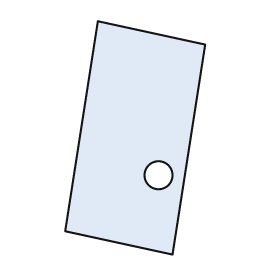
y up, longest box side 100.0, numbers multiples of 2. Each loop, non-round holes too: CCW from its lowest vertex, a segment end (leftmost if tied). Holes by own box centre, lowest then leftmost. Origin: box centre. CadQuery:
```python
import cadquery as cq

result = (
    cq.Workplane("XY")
    .moveTo(16.0, -50.0)
    .lineTo(30.0, 40.0)
    .lineTo(-16.0, 50.0)
    .lineTo(-30.0, -40.0)
    .close()
    .moveTo(10.0, -16.0)
    .circle(6.0)
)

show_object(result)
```